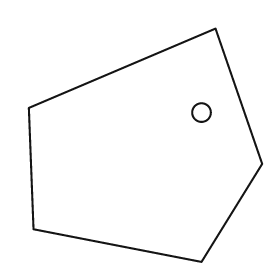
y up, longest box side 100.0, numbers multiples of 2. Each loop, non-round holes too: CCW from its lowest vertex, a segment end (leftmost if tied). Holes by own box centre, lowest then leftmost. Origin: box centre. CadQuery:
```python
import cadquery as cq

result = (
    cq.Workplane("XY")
    .moveTo(24.0, -50.0)
    .lineTo(50.0, -8.0)
    .lineTo(30.0, 50.0)
    .lineTo(-50.0, 16.0)
    .lineTo(-48.0, -36.0)
    .close()
    .moveTo(24.0, 14.0)
    .circle(4.0)
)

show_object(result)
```